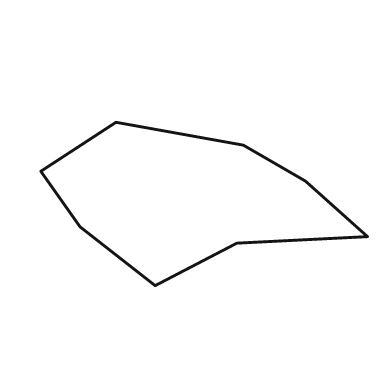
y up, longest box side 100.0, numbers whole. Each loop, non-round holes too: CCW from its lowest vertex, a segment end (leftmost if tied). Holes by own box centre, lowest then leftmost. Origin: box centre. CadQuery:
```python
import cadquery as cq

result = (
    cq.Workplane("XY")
    .moveTo(-15.0, -25.0)
    .lineTo(10.0, -12.0)
    .lineTo(50.0, -10.0)
    .lineTo(31.0, 7.0)
    .lineTo(12.0, 18.0)
    .lineTo(-27.0, 25.0)
    .lineTo(-50.0, 10.0)
    .lineTo(-38.0, -7.0)
    .close()
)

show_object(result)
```